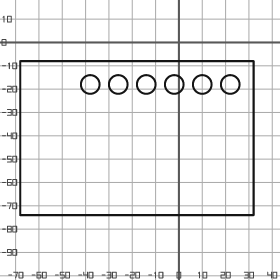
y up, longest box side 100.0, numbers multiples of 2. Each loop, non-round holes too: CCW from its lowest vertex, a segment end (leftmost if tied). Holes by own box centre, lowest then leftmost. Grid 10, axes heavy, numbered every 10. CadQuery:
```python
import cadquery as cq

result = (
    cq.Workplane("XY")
    .moveTo(-68.0, -74.0)
    .lineTo(32.0, -74.0)
    .lineTo(32.0, -8.0)
    .lineTo(-68.0, -8.0)
    .close()
    .moveTo(-38.0, -18.0)
    .circle(4.0)
    .moveTo(-26.0, -18.0)
    .circle(4.0)
    .moveTo(-14.0, -18.0)
    .circle(4.0)
    .moveTo(-2.0, -18.0)
    .circle(4.0)
    .moveTo(10.0, -18.0)
    .circle(4.0)
    .moveTo(22.0, -18.0)
    .circle(4.0)
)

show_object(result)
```